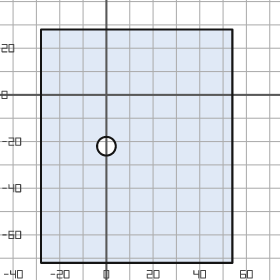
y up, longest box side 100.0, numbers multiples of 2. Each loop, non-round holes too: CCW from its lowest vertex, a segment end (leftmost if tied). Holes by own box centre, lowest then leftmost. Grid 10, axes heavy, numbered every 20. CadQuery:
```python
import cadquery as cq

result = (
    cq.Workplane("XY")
    .moveTo(-28.0, -72.0)
    .lineTo(54.0, -72.0)
    .lineTo(54.0, 28.0)
    .lineTo(-28.0, 28.0)
    .close()
    .moveTo(0.0, -22.0)
    .circle(4.0)
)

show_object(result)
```